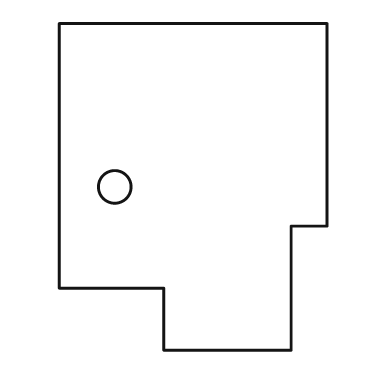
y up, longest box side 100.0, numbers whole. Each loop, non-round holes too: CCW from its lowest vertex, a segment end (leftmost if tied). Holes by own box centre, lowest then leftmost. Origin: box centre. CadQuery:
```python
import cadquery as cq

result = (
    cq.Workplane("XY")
    .moveTo(-9.0, -50.0)
    .lineTo(30.0, -50.0)
    .lineTo(30.0, -12.0)
    .lineTo(41.0, -12.0)
    .lineTo(41.0, 50.0)
    .lineTo(-41.0, 50.0)
    .lineTo(-41.0, -31.0)
    .lineTo(-9.0, -31.0)
    .close()
    .moveTo(-24.0, 0.0)
    .circle(5.0)
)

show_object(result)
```